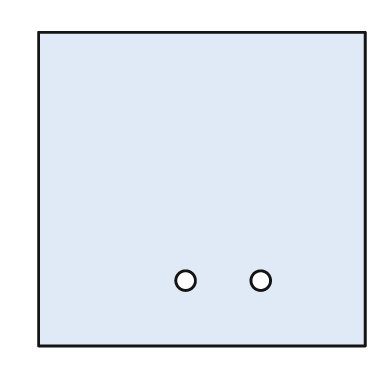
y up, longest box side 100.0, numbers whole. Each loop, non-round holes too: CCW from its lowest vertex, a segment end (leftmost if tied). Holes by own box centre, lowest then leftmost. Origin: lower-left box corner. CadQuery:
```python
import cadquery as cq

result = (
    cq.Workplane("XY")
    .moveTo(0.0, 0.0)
    .lineTo(100.0, 0.0)
    .lineTo(100.0, 96.0)
    .lineTo(0.0, 96.0)
    .close()
    .moveTo(45.0, 20.0)
    .circle(3.0)
    .moveTo(68.0, 20.0)
    .circle(3.0)
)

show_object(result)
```